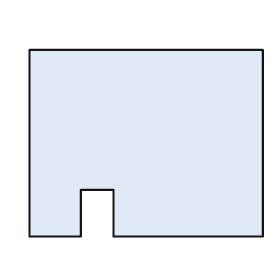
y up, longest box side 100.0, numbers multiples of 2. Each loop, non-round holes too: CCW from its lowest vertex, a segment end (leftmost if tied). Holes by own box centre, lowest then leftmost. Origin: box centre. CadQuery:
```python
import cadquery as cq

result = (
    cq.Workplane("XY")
    .moveTo(-50.0, -40.0)
    .lineTo(-28.0, -40.0)
    .lineTo(-28.0, -20.0)
    .lineTo(-14.0, -20.0)
    .lineTo(-14.0, -40.0)
    .lineTo(50.0, -40.0)
    .lineTo(50.0, 40.0)
    .lineTo(-50.0, 40.0)
    .close()
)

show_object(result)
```